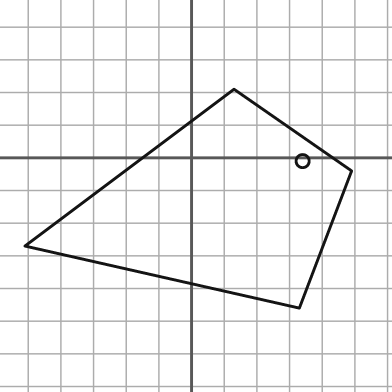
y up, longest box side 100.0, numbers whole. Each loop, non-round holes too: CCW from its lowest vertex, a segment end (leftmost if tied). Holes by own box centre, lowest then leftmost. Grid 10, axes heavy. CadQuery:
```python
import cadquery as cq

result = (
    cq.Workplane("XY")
    .moveTo(33.0, -46.0)
    .lineTo(49.0, -4.0)
    .lineTo(13.0, 21.0)
    .lineTo(-51.0, -27.0)
    .close()
    .moveTo(34.0, -1.0)
    .circle(2.0)
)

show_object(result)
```